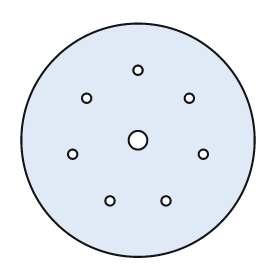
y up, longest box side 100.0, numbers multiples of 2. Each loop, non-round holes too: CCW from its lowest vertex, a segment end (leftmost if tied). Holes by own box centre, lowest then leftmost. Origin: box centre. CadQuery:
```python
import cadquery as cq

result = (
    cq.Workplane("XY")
    .moveTo(0.0, 0.0)
    .circle(50.0)
    .moveTo(-12.0, -26.0)
    .circle(2.0)
    .moveTo(12.0, -26.0)
    .circle(2.0)
    .moveTo(-28.0, -6.0)
    .circle(2.0)
    .moveTo(28.0, -6.0)
    .circle(2.0)
    .moveTo(0.0, 0.0)
    .circle(4.0)
    .moveTo(-22.0, 18.0)
    .circle(2.0)
    .moveTo(22.0, 18.0)
    .circle(2.0)
    .moveTo(0.0, 30.0)
    .circle(2.0)
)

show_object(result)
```